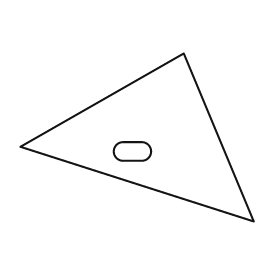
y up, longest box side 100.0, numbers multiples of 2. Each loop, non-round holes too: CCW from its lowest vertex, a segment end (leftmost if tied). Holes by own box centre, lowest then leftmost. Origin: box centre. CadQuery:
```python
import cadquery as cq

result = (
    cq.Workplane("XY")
    .moveTo(50.0, -36.0)
    .lineTo(20.0, 36.0)
    .lineTo(-50.0, -4.0)
    .close()
    .moveTo(-6.0, -10.0)
    .lineTo(2.0, -10.0)
    .threePointArc((6.0, -6.0), (2.0, -2.0))
    .lineTo(-6.0, -2.0)
    .threePointArc((-10.0, -6.0), (-6.0, -10.0))
    .close()
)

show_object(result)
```